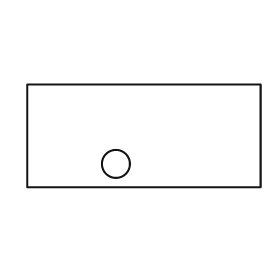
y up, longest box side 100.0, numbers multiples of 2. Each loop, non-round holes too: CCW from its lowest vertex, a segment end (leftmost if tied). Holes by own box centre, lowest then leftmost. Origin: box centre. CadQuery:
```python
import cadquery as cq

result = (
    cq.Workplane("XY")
    .moveTo(-50.0, -22.0)
    .lineTo(50.0, -22.0)
    .lineTo(50.0, 22.0)
    .lineTo(-50.0, 22.0)
    .close()
    .moveTo(-12.0, -12.0)
    .circle(6.0)
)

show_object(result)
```